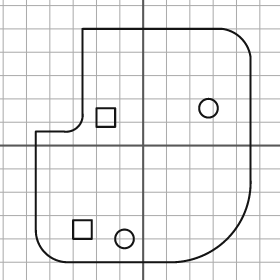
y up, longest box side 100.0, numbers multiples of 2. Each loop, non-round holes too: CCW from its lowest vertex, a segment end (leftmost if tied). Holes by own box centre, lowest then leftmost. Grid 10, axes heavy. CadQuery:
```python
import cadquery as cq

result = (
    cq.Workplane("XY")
    .moveTo(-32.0, -50.0)
    .lineTo(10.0, -50.0)
    .threePointArc((36.0, -40.0), (46.0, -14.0))
    .lineTo(46.0, 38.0)
    .threePointArc((42.0, 46.0), (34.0, 50.0))
    .lineTo(-26.0, 50.0)
    .lineTo(-26.0, 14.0)
    .threePointArc((-28.0, 8.0), (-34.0, 6.0))
    .lineTo(-46.0, 6.0)
    .lineTo(-46.0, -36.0)
    .threePointArc((-42.0, -46.0), (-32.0, -50.0))
    .close()
    .moveTo(-8.0, -40.0)
    .circle(4.0)
    .moveTo(-30.0, -40.0)
    .lineTo(-22.0, -40.0)
    .lineTo(-22.0, -32.0)
    .lineTo(-30.0, -32.0)
    .close()
    .moveTo(-20.0, 8.0)
    .lineTo(-12.0, 8.0)
    .lineTo(-12.0, 16.0)
    .lineTo(-20.0, 16.0)
    .close()
    .moveTo(28.0, 16.0)
    .circle(4.0)
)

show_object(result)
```